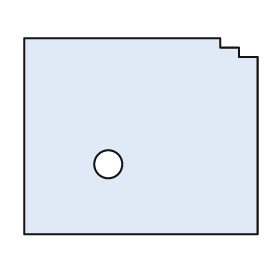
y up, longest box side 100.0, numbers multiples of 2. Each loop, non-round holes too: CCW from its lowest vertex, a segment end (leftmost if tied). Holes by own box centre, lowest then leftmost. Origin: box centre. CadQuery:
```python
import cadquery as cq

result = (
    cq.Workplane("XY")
    .moveTo(-50.0, -42.0)
    .lineTo(50.0, -42.0)
    .lineTo(50.0, 34.0)
    .lineTo(42.0, 34.0)
    .lineTo(42.0, 38.0)
    .lineTo(34.0, 38.0)
    .lineTo(34.0, 42.0)
    .lineTo(-50.0, 42.0)
    .close()
    .moveTo(-14.0, -12.0)
    .circle(6.0)
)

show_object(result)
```